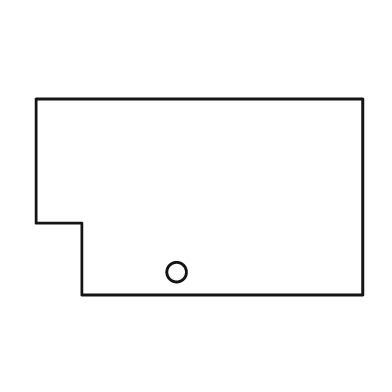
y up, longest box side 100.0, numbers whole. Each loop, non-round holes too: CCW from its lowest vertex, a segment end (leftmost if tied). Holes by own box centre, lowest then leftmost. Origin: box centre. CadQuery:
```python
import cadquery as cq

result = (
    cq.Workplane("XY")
    .moveTo(-36.0, -30.0)
    .lineTo(50.0, -30.0)
    .lineTo(50.0, 30.0)
    .lineTo(-50.0, 30.0)
    .lineTo(-50.0, -8.0)
    .lineTo(-36.0, -8.0)
    .close()
    .moveTo(-7.0, -23.0)
    .circle(3.0)
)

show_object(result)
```